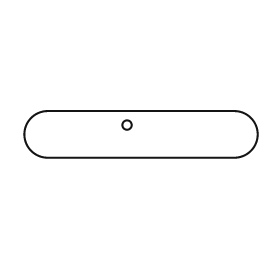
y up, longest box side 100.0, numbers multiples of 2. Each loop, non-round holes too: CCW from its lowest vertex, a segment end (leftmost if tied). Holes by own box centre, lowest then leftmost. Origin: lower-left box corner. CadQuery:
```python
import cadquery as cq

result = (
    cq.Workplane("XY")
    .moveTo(10.0, 0.0)
    .lineTo(90.0, 0.0)
    .threePointArc((100.0, 10.0), (90.0, 20.0))
    .lineTo(10.0, 20.0)
    .threePointArc((0.0, 10.0), (10.0, 0.0))
    .close()
    .moveTo(44.0, 14.0)
    .circle(2.0)
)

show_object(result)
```